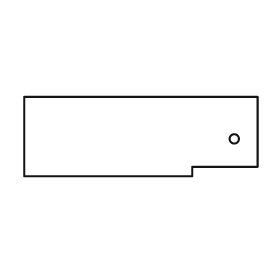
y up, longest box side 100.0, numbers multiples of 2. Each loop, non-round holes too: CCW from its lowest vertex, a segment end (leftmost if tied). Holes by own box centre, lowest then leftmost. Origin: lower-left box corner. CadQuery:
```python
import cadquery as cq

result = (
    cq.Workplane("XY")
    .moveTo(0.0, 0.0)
    .lineTo(72.0, 0.0)
    .lineTo(72.0, 4.0)
    .lineTo(100.0, 4.0)
    .lineTo(100.0, 34.0)
    .lineTo(0.0, 34.0)
    .close()
    .moveTo(90.0, 16.0)
    .circle(2.0)
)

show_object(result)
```